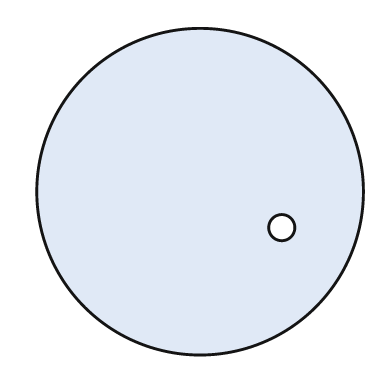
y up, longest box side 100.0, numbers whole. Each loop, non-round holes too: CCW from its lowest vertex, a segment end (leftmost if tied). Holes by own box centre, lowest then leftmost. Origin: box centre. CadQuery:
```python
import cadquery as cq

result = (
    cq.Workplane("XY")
    .moveTo(0.0, 0.0)
    .circle(50.0)
    .moveTo(25.0, -11.0)
    .circle(4.0)
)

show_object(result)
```